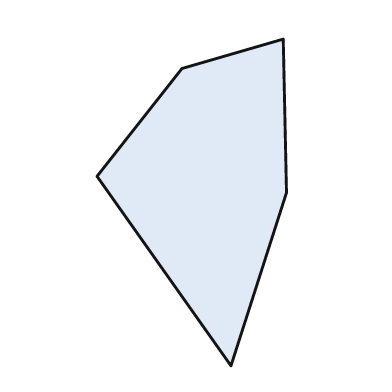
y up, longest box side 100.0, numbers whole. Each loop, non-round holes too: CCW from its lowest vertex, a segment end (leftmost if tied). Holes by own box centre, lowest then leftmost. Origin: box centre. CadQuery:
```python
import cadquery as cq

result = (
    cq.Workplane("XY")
    .moveTo(12.0, -50.0)
    .lineTo(29.0, 3.0)
    .lineTo(28.0, 50.0)
    .lineTo(-3.0, 41.0)
    .lineTo(-29.0, 8.0)
    .close()
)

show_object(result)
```